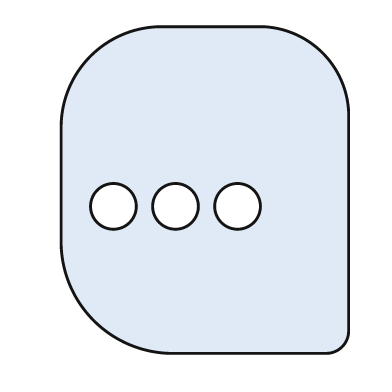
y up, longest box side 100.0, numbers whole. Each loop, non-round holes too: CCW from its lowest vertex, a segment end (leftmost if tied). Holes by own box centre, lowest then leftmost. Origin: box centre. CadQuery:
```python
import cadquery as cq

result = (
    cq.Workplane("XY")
    .moveTo(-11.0, -50.0)
    .lineTo(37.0, -50.0)
    .threePointArc((42.0, -48.0), (44.0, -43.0))
    .lineTo(44.0, 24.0)
    .threePointArc((36.0, 42.0), (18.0, 50.0))
    .lineTo(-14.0, 50.0)
    .threePointArc((-35.0, 41.0), (-44.0, 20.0))
    .lineTo(-44.0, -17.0)
    .threePointArc((-34.0, -40.0), (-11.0, -50.0))
    .close()
    .moveTo(-28.0, -5.0)
    .circle(7.0)
    .moveTo(-9.0, -5.0)
    .circle(7.0)
    .moveTo(10.0, -5.0)
    .circle(7.0)
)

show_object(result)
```